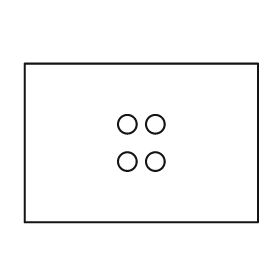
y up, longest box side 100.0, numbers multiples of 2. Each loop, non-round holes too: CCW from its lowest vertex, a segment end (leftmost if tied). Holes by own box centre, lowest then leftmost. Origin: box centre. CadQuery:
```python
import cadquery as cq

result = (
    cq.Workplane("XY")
    .moveTo(-50.0, -34.0)
    .lineTo(50.0, -34.0)
    .lineTo(50.0, 34.0)
    .lineTo(-50.0, 34.0)
    .close()
    .moveTo(-6.0, -8.0)
    .circle(4.0)
    .moveTo(6.0, -8.0)
    .circle(4.0)
    .moveTo(-6.0, 8.0)
    .circle(4.0)
    .moveTo(6.0, 8.0)
    .circle(4.0)
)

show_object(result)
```